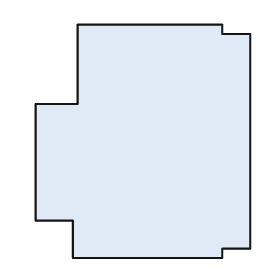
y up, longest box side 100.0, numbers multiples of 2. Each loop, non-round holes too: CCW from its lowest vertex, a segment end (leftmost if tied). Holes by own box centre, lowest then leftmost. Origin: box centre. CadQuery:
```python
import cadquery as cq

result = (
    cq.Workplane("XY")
    .moveTo(-30.0, -50.0)
    .lineTo(34.0, -50.0)
    .lineTo(34.0, -46.0)
    .lineTo(46.0, -46.0)
    .lineTo(46.0, 46.0)
    .lineTo(34.0, 46.0)
    .lineTo(34.0, 50.0)
    .lineTo(-28.0, 50.0)
    .lineTo(-28.0, 16.0)
    .lineTo(-46.0, 16.0)
    .lineTo(-46.0, -34.0)
    .lineTo(-30.0, -34.0)
    .close()
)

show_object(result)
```